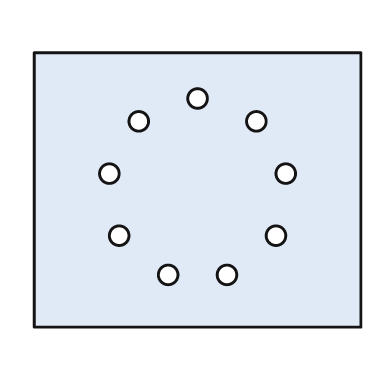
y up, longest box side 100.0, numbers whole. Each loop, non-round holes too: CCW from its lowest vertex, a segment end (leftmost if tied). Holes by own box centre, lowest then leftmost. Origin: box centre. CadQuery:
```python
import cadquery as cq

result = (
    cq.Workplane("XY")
    .moveTo(-50.0, -42.0)
    .lineTo(50.0, -42.0)
    .lineTo(50.0, 42.0)
    .lineTo(-50.0, 42.0)
    .close()
    .moveTo(-9.0, -26.0)
    .circle(3.0)
    .moveTo(9.0, -26.0)
    .circle(3.0)
    .moveTo(-24.0, -14.0)
    .circle(3.0)
    .moveTo(24.0, -14.0)
    .circle(3.0)
    .moveTo(-27.0, 5.0)
    .circle(3.0)
    .moveTo(27.0, 5.0)
    .circle(3.0)
    .moveTo(-18.0, 21.0)
    .circle(3.0)
    .moveTo(18.0, 21.0)
    .circle(3.0)
    .moveTo(0.0, 28.0)
    .circle(3.0)
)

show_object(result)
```